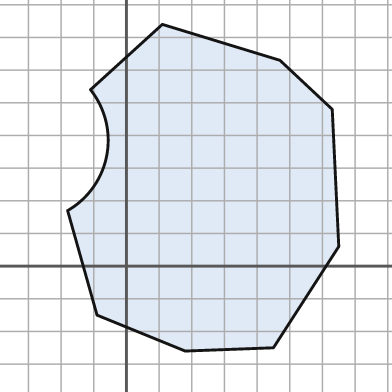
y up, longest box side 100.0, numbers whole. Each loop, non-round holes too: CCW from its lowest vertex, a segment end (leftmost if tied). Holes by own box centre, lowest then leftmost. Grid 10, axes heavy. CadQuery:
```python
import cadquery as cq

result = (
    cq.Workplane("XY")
    .moveTo(18.0, -26.0)
    .lineTo(45.0, -25.0)
    .lineTo(65.0, 6.0)
    .lineTo(63.0, 48.0)
    .lineTo(47.0, 63.0)
    .lineTo(11.0, 74.0)
    .lineTo(-11.0, 54.0)
    .threePointArc((-6.0, 34.0), (-18.0, 17.0))
    .lineTo(-9.0, -15.0)
    .close()
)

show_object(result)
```